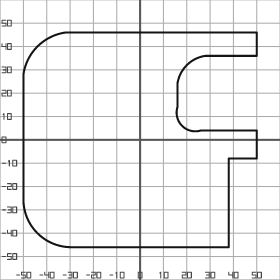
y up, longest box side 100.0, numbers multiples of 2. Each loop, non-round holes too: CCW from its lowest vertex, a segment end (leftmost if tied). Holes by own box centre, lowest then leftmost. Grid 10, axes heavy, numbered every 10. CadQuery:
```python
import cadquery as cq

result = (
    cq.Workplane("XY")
    .moveTo(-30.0, -46.0)
    .lineTo(38.0, -46.0)
    .lineTo(38.0, -8.0)
    .lineTo(50.0, -8.0)
    .lineTo(50.0, 4.0)
    .lineTo(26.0, 4.0)
    .threePointArc((18.0, 6.0), (16.0, 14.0))
    .lineTo(16.0, 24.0)
    .threePointArc((20.0, 32.0), (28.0, 36.0))
    .lineTo(50.0, 36.0)
    .lineTo(50.0, 46.0)
    .lineTo(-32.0, 46.0)
    .threePointArc((-44.0, 40.0), (-50.0, 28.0))
    .lineTo(-50.0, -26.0)
    .threePointArc((-44.0, -40.0), (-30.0, -46.0))
    .close()
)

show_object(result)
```